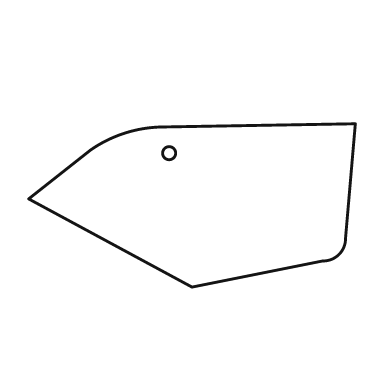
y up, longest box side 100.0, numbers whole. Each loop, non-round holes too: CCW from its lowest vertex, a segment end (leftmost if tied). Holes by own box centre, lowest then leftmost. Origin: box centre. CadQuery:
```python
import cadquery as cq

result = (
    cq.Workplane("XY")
    .moveTo(0.0, -25.0)
    .lineTo(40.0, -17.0)
    .threePointArc((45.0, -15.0), (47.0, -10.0))
    .lineTo(50.0, 25.0)
    .lineTo(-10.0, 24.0)
    .threePointArc((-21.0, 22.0), (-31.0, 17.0))
    .lineTo(-50.0, 2.0)
    .close()
    .moveTo(-7.0, 16.0)
    .circle(2.0)
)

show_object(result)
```